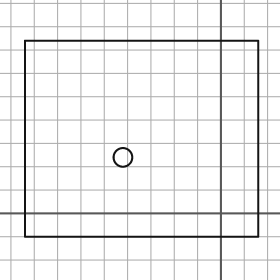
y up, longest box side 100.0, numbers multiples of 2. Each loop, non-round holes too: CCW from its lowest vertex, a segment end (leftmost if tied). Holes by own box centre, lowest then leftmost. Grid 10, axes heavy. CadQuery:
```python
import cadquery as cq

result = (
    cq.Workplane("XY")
    .moveTo(-84.0, -10.0)
    .lineTo(16.0, -10.0)
    .lineTo(16.0, 74.0)
    .lineTo(-84.0, 74.0)
    .close()
    .moveTo(-42.0, 24.0)
    .circle(4.0)
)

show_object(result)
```